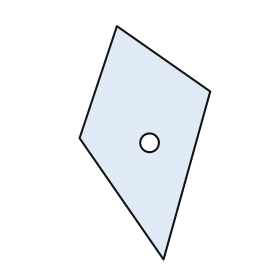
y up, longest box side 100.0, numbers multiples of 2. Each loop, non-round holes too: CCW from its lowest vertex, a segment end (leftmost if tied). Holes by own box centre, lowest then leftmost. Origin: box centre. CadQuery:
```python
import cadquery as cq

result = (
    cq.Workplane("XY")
    .moveTo(8.0, -50.0)
    .lineTo(28.0, 22.0)
    .lineTo(-12.0, 50.0)
    .lineTo(-28.0, 2.0)
    .close()
    .moveTo(2.0, 0.0)
    .circle(4.0)
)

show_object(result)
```